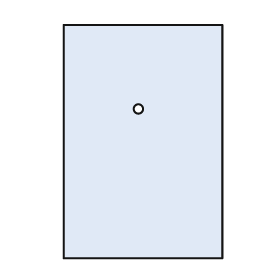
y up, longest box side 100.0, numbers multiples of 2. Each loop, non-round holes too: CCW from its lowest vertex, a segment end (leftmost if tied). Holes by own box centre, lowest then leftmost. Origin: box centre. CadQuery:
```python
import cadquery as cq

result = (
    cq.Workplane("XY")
    .moveTo(-34.0, -50.0)
    .lineTo(34.0, -50.0)
    .lineTo(34.0, 50.0)
    .lineTo(-34.0, 50.0)
    .close()
    .moveTo(-2.0, 14.0)
    .circle(2.0)
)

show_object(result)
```